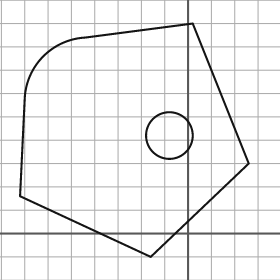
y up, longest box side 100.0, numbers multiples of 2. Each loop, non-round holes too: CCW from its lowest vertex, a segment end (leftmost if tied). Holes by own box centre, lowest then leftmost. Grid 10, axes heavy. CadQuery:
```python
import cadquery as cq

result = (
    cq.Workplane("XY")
    .moveTo(-16.0, -10.0)
    .lineTo(26.0, 30.0)
    .lineTo(2.0, 90.0)
    .lineTo(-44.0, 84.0)
    .threePointArc((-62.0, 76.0), (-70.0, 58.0))
    .lineTo(-72.0, 16.0)
    .close()
    .moveTo(-8.0, 42.0)
    .circle(10.0)
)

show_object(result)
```